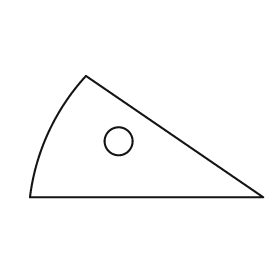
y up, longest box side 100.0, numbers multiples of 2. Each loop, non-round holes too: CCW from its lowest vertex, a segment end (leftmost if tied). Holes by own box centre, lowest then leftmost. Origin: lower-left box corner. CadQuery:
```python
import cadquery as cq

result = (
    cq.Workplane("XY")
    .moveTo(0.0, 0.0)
    .lineTo(100.0, 0.0)
    .lineTo(24.0, 52.0)
    .threePointArc((8.0, 28.0), (0.0, 0.0))
    .close()
    .moveTo(38.0, 24.0)
    .circle(6.0)
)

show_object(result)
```